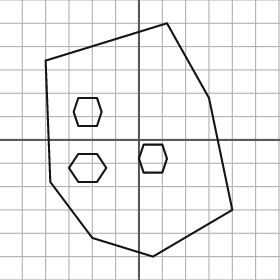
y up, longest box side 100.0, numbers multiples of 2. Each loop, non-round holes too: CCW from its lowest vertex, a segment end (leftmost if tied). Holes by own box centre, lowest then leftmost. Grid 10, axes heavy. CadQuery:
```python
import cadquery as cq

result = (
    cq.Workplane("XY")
    .moveTo(6.0, -50.0)
    .lineTo(40.0, -30.0)
    .lineTo(30.0, 18.0)
    .lineTo(12.0, 50.0)
    .lineTo(-40.0, 34.0)
    .lineTo(-38.0, -18.0)
    .lineTo(-20.0, -42.0)
    .close()
    .moveTo(-26.0, -18.0)
    .lineTo(-18.0, -18.0)
    .lineTo(-14.0, -12.0)
    .lineTo(-18.0, -6.0)
    .lineTo(-26.0, -6.0)
    .lineTo(-30.0, -12.0)
    .close()
    .moveTo(2.0, -14.0)
    .lineTo(10.0, -14.0)
    .lineTo(12.0, -8.0)
    .lineTo(10.0, -2.0)
    .lineTo(2.0, -2.0)
    .lineTo(0.0, -8.0)
    .close()
    .moveTo(-26.0, 6.0)
    .lineTo(-18.0, 6.0)
    .lineTo(-16.0, 12.0)
    .lineTo(-18.0, 18.0)
    .lineTo(-26.0, 18.0)
    .lineTo(-28.0, 12.0)
    .close()
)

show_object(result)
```